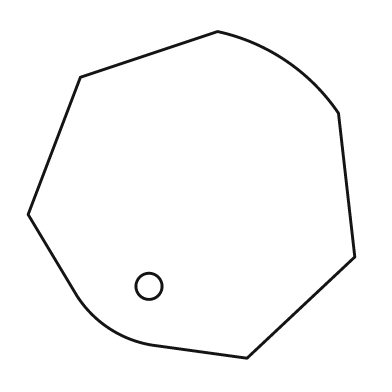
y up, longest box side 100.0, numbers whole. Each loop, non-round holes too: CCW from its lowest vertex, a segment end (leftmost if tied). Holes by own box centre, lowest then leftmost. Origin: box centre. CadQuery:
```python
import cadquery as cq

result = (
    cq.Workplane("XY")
    .moveTo(17.0, -50.0)
    .lineTo(50.0, -19.0)
    .lineTo(45.0, 25.0)
    .threePointArc((29.0, 41.0), (8.0, 50.0))
    .lineTo(-34.0, 36.0)
    .lineTo(-50.0, -6.0)
    .lineTo(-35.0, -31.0)
    .threePointArc((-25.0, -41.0), (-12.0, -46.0))
    .close()
    .moveTo(-13.0, -28.0)
    .circle(4.0)
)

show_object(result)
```